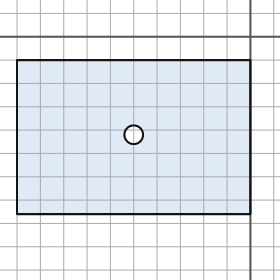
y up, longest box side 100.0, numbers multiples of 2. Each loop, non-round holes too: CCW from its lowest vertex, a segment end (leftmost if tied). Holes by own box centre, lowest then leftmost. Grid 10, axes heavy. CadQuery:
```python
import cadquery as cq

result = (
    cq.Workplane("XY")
    .moveTo(-100.0, -76.0)
    .lineTo(0.0, -76.0)
    .lineTo(0.0, -10.0)
    .lineTo(-100.0, -10.0)
    .close()
    .moveTo(-50.0, -42.0)
    .circle(4.0)
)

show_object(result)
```